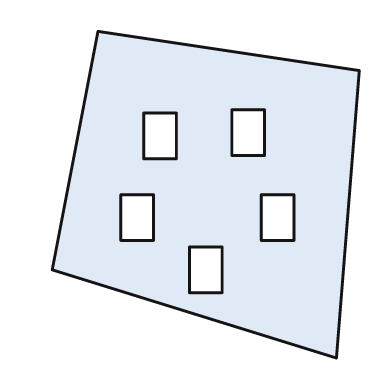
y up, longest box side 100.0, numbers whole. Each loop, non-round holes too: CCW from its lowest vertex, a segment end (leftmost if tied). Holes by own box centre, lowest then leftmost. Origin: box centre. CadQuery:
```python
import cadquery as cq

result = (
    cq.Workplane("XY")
    .moveTo(40.0, -50.0)
    .lineTo(47.0, 38.0)
    .lineTo(-33.0, 50.0)
    .lineTo(-47.0, -23.0)
    .close()
    .moveTo(-5.0, -30.0)
    .lineTo(5.0, -30.0)
    .lineTo(5.0, -16.0)
    .lineTo(-5.0, -16.0)
    .close()
    .moveTo(-26.0, -14.0)
    .lineTo(-16.0, -14.0)
    .lineTo(-16.0, 0.0)
    .lineTo(-26.0, 0.0)
    .close()
    .moveTo(17.0, -14.0)
    .lineTo(27.0, -14.0)
    .lineTo(27.0, 0.0)
    .lineTo(17.0, 0.0)
    .close()
    .moveTo(-19.0, 11.0)
    .lineTo(-9.0, 11.0)
    .lineTo(-9.0, 25.0)
    .lineTo(-19.0, 25.0)
    .close()
    .moveTo(8.0, 12.0)
    .lineTo(18.0, 12.0)
    .lineTo(18.0, 26.0)
    .lineTo(8.0, 26.0)
    .close()
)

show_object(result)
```